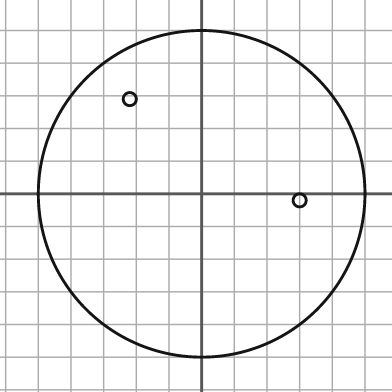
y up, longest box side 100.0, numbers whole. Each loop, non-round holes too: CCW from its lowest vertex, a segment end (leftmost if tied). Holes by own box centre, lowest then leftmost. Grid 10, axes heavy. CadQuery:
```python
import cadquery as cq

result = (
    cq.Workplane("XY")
    .moveTo(0.0, 0.0)
    .circle(50.0)
    .moveTo(30.0, -2.0)
    .circle(2.0)
    .moveTo(-22.0, 29.0)
    .circle(2.0)
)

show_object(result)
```